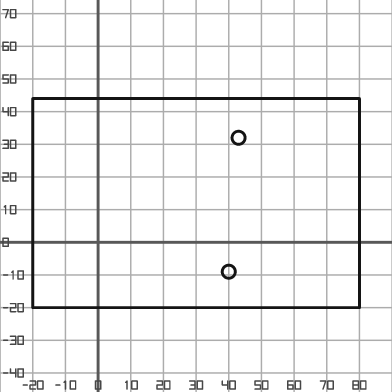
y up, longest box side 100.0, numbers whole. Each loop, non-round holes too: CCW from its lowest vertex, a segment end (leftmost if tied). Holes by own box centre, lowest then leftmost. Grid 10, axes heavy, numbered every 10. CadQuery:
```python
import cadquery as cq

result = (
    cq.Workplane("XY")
    .moveTo(-20.0, -20.0)
    .lineTo(80.0, -20.0)
    .lineTo(80.0, 44.0)
    .lineTo(-20.0, 44.0)
    .close()
    .moveTo(40.0, -9.0)
    .circle(2.0)
    .moveTo(43.0, 32.0)
    .circle(2.0)
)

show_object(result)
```